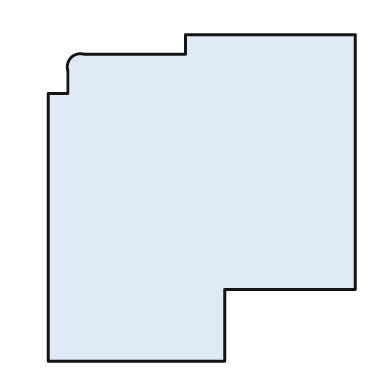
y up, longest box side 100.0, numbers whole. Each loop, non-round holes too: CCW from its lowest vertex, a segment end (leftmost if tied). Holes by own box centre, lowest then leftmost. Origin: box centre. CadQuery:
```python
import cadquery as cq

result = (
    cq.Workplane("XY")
    .moveTo(-47.0, -50.0)
    .lineTo(7.0, -50.0)
    .lineTo(7.0, -28.0)
    .lineTo(47.0, -28.0)
    .lineTo(47.0, 50.0)
    .lineTo(-5.0, 50.0)
    .lineTo(-5.0, 44.0)
    .lineTo(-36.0, 44.0)
    .threePointArc((-40.0, 43.0), (-41.0, 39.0))
    .lineTo(-41.0, 32.0)
    .lineTo(-47.0, 32.0)
    .close()
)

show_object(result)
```